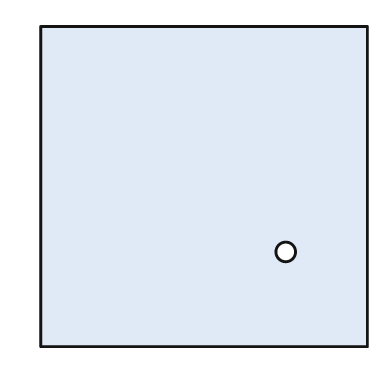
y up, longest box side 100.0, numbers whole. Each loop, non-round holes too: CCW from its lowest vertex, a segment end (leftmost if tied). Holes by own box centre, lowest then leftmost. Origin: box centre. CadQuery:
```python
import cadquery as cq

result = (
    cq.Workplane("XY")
    .moveTo(-50.0, -49.0)
    .lineTo(50.0, -49.0)
    .lineTo(50.0, 49.0)
    .lineTo(-50.0, 49.0)
    .close()
    .moveTo(25.0, -20.0)
    .circle(3.0)
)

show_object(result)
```